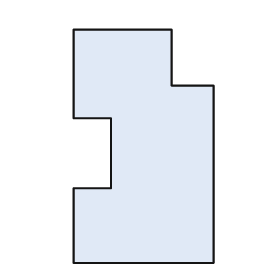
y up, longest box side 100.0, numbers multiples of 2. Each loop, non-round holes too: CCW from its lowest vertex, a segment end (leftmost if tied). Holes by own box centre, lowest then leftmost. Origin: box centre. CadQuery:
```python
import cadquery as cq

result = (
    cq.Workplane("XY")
    .moveTo(-30.0, -50.0)
    .lineTo(30.0, -50.0)
    .lineTo(30.0, 26.0)
    .lineTo(12.0, 26.0)
    .lineTo(12.0, 50.0)
    .lineTo(-30.0, 50.0)
    .lineTo(-30.0, 12.0)
    .lineTo(-14.0, 12.0)
    .lineTo(-14.0, -18.0)
    .lineTo(-30.0, -18.0)
    .close()
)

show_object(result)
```